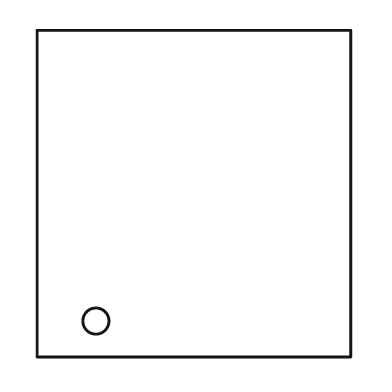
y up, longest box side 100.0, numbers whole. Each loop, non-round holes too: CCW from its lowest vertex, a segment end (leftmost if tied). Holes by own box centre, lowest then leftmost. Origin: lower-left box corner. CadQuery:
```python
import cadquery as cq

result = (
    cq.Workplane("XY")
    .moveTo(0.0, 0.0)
    .lineTo(96.0, 0.0)
    .lineTo(96.0, 100.0)
    .lineTo(0.0, 100.0)
    .close()
    .moveTo(18.0, 11.0)
    .circle(4.0)
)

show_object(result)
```